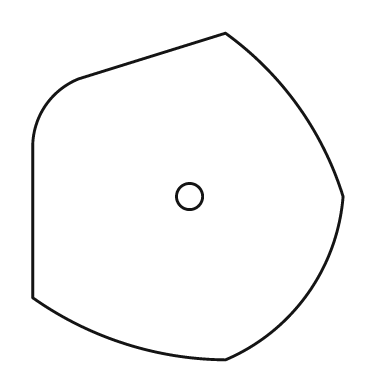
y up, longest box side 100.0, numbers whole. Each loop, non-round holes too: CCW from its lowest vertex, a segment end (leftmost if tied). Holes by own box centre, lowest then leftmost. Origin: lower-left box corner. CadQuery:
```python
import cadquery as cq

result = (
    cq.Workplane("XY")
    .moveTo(59.0, 0.0)
    .threePointArc((84.0, 20.0), (95.0, 50.0))
    .threePointArc((81.0, 78.0), (59.0, 100.0))
    .lineTo(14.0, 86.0)
    .threePointArc((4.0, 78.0), (0.0, 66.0))
    .lineTo(0.0, 19.0)
    .threePointArc((28.0, 5.0), (59.0, 0.0))
    .close()
    .moveTo(48.0, 50.0)
    .circle(4.0)
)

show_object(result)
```